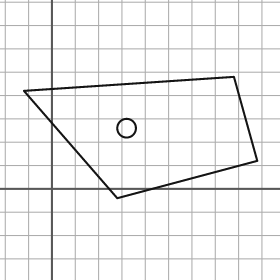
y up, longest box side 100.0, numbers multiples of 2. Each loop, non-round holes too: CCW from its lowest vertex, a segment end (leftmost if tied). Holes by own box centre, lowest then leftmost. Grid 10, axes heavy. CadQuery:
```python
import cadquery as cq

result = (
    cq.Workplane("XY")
    .moveTo(28.0, -4.0)
    .lineTo(88.0, 12.0)
    .lineTo(78.0, 48.0)
    .lineTo(-12.0, 42.0)
    .close()
    .moveTo(32.0, 26.0)
    .circle(4.0)
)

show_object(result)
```